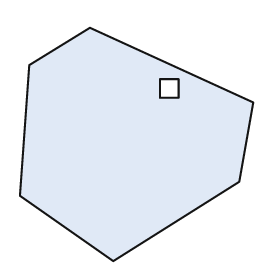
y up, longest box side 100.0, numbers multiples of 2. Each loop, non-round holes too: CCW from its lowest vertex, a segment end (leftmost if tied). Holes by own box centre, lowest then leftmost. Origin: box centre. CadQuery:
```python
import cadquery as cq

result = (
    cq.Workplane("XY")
    .moveTo(-10.0, -50.0)
    .lineTo(44.0, -16.0)
    .lineTo(50.0, 18.0)
    .lineTo(-20.0, 50.0)
    .lineTo(-46.0, 34.0)
    .lineTo(-50.0, -22.0)
    .close()
    .moveTo(10.0, 20.0)
    .lineTo(18.0, 20.0)
    .lineTo(18.0, 28.0)
    .lineTo(10.0, 28.0)
    .close()
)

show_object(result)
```